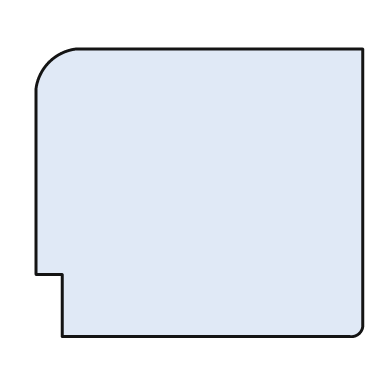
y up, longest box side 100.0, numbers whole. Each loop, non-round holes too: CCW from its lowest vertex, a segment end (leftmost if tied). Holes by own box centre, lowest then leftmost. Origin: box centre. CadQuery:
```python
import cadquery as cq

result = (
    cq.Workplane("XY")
    .moveTo(-42.0, -44.0)
    .lineTo(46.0, -44.0)
    .threePointArc((49.0, -43.0), (50.0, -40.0))
    .lineTo(50.0, 44.0)
    .lineTo(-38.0, 44.0)
    .threePointArc((-46.0, 40.0), (-50.0, 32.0))
    .lineTo(-50.0, -25.0)
    .lineTo(-42.0, -25.0)
    .close()
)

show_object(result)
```